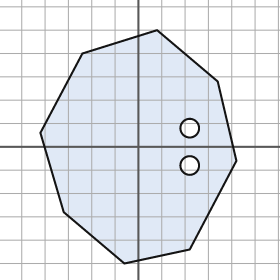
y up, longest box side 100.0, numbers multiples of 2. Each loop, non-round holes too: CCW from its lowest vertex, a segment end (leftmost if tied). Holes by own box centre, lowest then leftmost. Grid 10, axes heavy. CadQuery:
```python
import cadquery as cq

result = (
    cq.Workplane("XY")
    .moveTo(-6.0, -50.0)
    .lineTo(22.0, -44.0)
    .lineTo(42.0, -6.0)
    .lineTo(34.0, 28.0)
    .lineTo(8.0, 50.0)
    .lineTo(-24.0, 40.0)
    .lineTo(-42.0, 6.0)
    .lineTo(-32.0, -28.0)
    .close()
    .moveTo(22.0, -8.0)
    .circle(4.0)
    .moveTo(22.0, 8.0)
    .circle(4.0)
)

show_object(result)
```